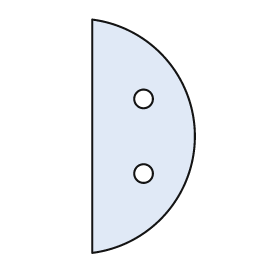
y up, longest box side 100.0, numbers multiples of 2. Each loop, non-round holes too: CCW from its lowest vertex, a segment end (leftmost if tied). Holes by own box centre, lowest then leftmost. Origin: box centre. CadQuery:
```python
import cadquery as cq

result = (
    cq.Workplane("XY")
    .moveTo(-22.0, -50.0)
    .threePointArc((22.0, 0.0), (-22.0, 50.0))
    .close()
    .moveTo(0.0, -16.0)
    .circle(4.0)
    .moveTo(0.0, 16.0)
    .circle(4.0)
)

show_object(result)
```